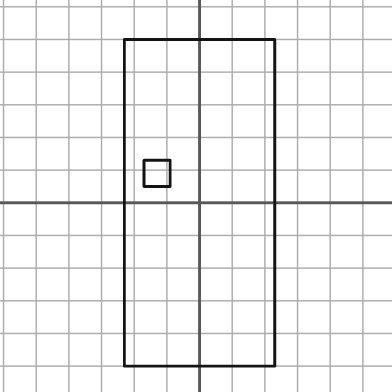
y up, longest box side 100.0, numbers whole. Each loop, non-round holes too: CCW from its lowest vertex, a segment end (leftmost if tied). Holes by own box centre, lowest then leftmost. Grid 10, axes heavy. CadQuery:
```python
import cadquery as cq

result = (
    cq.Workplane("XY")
    .moveTo(-23.0, -50.0)
    .lineTo(23.0, -50.0)
    .lineTo(23.0, 50.0)
    .lineTo(-23.0, 50.0)
    .close()
    .moveTo(-17.0, 5.0)
    .lineTo(-9.0, 5.0)
    .lineTo(-9.0, 13.0)
    .lineTo(-17.0, 13.0)
    .close()
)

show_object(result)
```